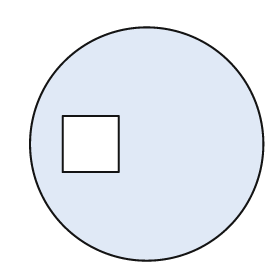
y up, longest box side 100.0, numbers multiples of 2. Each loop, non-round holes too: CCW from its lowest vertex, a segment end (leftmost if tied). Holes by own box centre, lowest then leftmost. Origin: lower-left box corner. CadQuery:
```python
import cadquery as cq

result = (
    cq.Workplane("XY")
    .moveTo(50.0, 50.0)
    .circle(50.0)
    .moveTo(14.0, 38.0)
    .lineTo(38.0, 38.0)
    .lineTo(38.0, 62.0)
    .lineTo(14.0, 62.0)
    .close()
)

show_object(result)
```